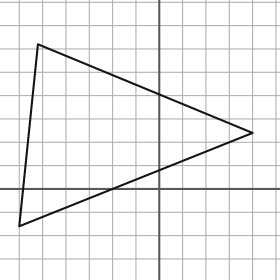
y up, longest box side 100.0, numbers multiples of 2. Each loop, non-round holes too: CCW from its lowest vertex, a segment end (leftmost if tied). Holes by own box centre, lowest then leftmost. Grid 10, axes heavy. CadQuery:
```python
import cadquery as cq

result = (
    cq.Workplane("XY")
    .moveTo(-60.0, -16.0)
    .lineTo(40.0, 24.0)
    .lineTo(-52.0, 62.0)
    .close()
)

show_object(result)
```